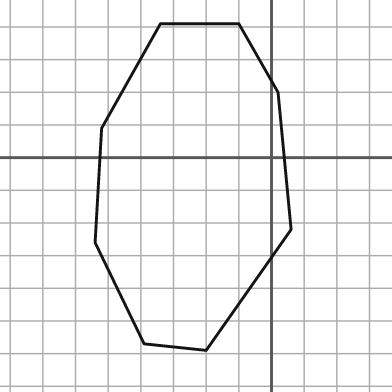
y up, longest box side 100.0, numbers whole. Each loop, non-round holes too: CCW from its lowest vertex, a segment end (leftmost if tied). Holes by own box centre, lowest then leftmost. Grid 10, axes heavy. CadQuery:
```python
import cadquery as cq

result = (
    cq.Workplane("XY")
    .moveTo(-20.0, -59.0)
    .lineTo(6.0, -22.0)
    .lineTo(2.0, 20.0)
    .lineTo(-10.0, 41.0)
    .lineTo(-34.0, 41.0)
    .lineTo(-52.0, 9.0)
    .lineTo(-54.0, -26.0)
    .lineTo(-39.0, -57.0)
    .close()
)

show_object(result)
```